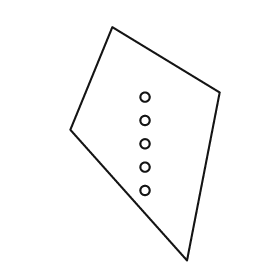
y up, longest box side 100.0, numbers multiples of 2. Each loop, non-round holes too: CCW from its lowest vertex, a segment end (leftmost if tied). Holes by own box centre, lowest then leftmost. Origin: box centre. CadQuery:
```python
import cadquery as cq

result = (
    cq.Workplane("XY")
    .moveTo(18.0, -50.0)
    .lineTo(32.0, 22.0)
    .lineTo(-14.0, 50.0)
    .lineTo(-32.0, 6.0)
    .close()
    .moveTo(0.0, -20.0)
    .circle(2.0)
    .moveTo(0.0, -10.0)
    .circle(2.0)
    .moveTo(0.0, 0.0)
    .circle(2.0)
    .moveTo(0.0, 10.0)
    .circle(2.0)
    .moveTo(0.0, 20.0)
    .circle(2.0)
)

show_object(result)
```